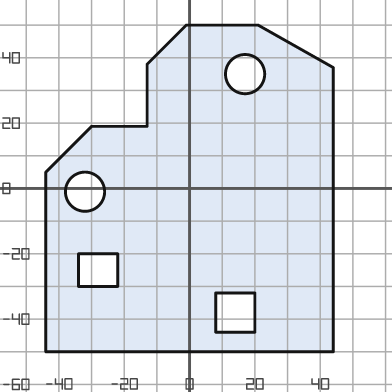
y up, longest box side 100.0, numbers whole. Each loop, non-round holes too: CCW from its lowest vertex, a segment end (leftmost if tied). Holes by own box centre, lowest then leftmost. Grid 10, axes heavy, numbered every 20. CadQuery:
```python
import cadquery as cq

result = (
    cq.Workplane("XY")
    .moveTo(-44.0, -50.0)
    .lineTo(44.0, -50.0)
    .lineTo(44.0, 37.0)
    .lineTo(21.0, 50.0)
    .lineTo(-1.0, 50.0)
    .lineTo(-13.0, 38.0)
    .lineTo(-13.0, 19.0)
    .lineTo(-30.0, 19.0)
    .lineTo(-44.0, 5.0)
    .close()
    .moveTo(8.0, -44.0)
    .lineTo(20.0, -44.0)
    .lineTo(20.0, -32.0)
    .lineTo(8.0, -32.0)
    .close()
    .moveTo(-34.0, -30.0)
    .lineTo(-22.0, -30.0)
    .lineTo(-22.0, -20.0)
    .lineTo(-34.0, -20.0)
    .close()
    .moveTo(-32.0, -1.0)
    .circle(6.0)
    .moveTo(17.0, 35.0)
    .circle(6.0)
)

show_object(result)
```